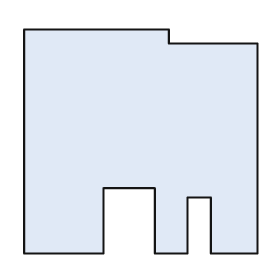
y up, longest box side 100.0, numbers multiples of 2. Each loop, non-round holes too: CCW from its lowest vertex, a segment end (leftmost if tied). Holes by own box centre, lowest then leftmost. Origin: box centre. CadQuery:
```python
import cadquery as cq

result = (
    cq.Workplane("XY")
    .moveTo(-50.0, -48.0)
    .lineTo(-16.0, -48.0)
    .lineTo(-16.0, -20.0)
    .lineTo(6.0, -20.0)
    .lineTo(6.0, -48.0)
    .lineTo(20.0, -48.0)
    .lineTo(20.0, -24.0)
    .lineTo(30.0, -24.0)
    .lineTo(30.0, -48.0)
    .lineTo(50.0, -48.0)
    .lineTo(50.0, 42.0)
    .lineTo(12.0, 42.0)
    .lineTo(12.0, 48.0)
    .lineTo(-50.0, 48.0)
    .close()
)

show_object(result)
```